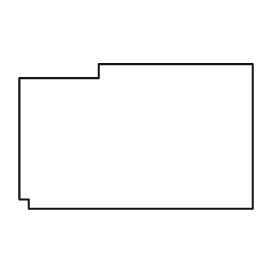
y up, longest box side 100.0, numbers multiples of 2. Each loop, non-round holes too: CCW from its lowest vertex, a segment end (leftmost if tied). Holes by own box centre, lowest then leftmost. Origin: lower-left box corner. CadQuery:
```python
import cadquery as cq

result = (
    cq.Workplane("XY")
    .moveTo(4.0, 0.0)
    .lineTo(100.0, 0.0)
    .lineTo(100.0, 62.0)
    .lineTo(34.0, 62.0)
    .lineTo(34.0, 56.0)
    .lineTo(0.0, 56.0)
    .lineTo(0.0, 4.0)
    .lineTo(4.0, 4.0)
    .close()
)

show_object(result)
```